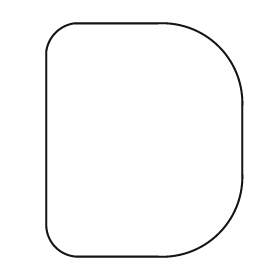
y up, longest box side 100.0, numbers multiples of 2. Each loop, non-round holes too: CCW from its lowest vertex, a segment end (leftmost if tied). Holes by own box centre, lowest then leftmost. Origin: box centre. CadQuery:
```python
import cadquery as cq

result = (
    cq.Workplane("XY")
    .moveTo(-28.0, -50.0)
    .lineTo(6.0, -50.0)
    .threePointArc((32.0, -40.0), (42.0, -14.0))
    .lineTo(42.0, 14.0)
    .threePointArc((32.0, 40.0), (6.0, 50.0))
    .lineTo(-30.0, 50.0)
    .threePointArc((-38.0, 46.0), (-42.0, 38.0))
    .lineTo(-42.0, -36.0)
    .threePointArc((-38.0, -46.0), (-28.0, -50.0))
    .close()
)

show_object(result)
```